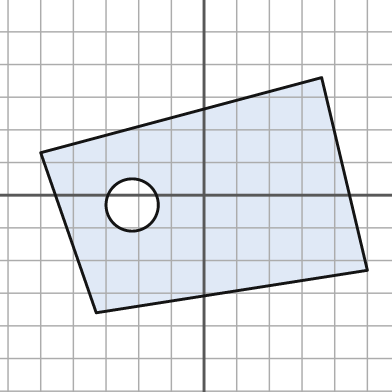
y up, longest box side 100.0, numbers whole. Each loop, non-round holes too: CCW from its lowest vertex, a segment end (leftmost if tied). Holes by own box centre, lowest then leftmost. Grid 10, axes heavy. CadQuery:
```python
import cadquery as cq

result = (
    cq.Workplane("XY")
    .moveTo(-33.0, -36.0)
    .lineTo(50.0, -23.0)
    .lineTo(36.0, 36.0)
    .lineTo(-50.0, 13.0)
    .close()
    .moveTo(-22.0, -3.0)
    .circle(8.0)
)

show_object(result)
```